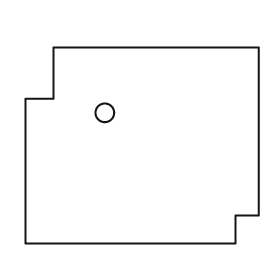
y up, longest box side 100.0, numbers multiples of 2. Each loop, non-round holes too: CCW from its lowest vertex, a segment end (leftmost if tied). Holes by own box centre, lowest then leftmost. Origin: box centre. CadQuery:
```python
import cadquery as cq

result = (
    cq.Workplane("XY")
    .moveTo(-50.0, -42.0)
    .lineTo(40.0, -42.0)
    .lineTo(40.0, -30.0)
    .lineTo(50.0, -30.0)
    .lineTo(50.0, 42.0)
    .lineTo(-38.0, 42.0)
    .lineTo(-38.0, 20.0)
    .lineTo(-50.0, 20.0)
    .close()
    .moveTo(-16.0, 14.0)
    .circle(4.0)
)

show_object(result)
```